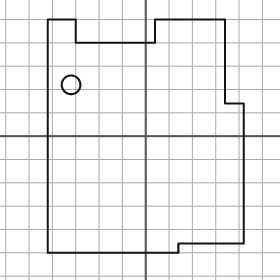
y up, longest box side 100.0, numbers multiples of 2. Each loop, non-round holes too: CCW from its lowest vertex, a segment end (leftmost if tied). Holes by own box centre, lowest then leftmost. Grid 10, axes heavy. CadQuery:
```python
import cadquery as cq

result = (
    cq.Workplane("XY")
    .moveTo(-42.0, -50.0)
    .lineTo(14.0, -50.0)
    .lineTo(14.0, -46.0)
    .lineTo(42.0, -46.0)
    .lineTo(42.0, 14.0)
    .lineTo(34.0, 14.0)
    .lineTo(34.0, 50.0)
    .lineTo(4.0, 50.0)
    .lineTo(4.0, 40.0)
    .lineTo(-30.0, 40.0)
    .lineTo(-30.0, 50.0)
    .lineTo(-42.0, 50.0)
    .close()
    .moveTo(-32.0, 22.0)
    .circle(4.0)
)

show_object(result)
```